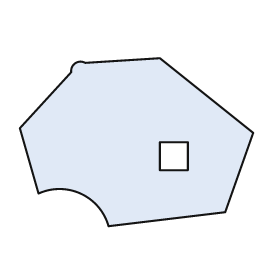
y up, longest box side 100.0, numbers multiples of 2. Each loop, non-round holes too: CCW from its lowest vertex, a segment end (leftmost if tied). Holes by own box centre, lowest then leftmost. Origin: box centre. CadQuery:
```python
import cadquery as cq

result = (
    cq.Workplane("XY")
    .moveTo(-12.0, -36.0)
    .lineTo(38.0, -30.0)
    .lineTo(50.0, 4.0)
    .lineTo(10.0, 36.0)
    .lineTo(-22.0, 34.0)
    .threePointArc((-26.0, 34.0), (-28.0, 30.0))
    .lineTo(-50.0, 6.0)
    .lineTo(-42.0, -22.0)
    .threePointArc((-24.0, -22.0), (-12.0, -36.0))
    .close()
    .moveTo(10.0, -12.0)
    .lineTo(22.0, -12.0)
    .lineTo(22.0, 0.0)
    .lineTo(10.0, 0.0)
    .close()
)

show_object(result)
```